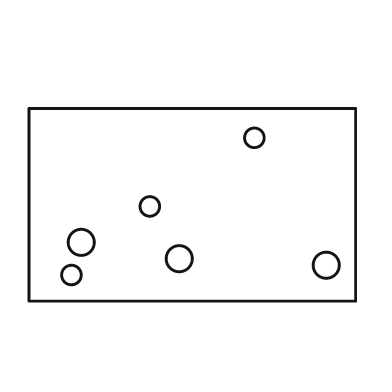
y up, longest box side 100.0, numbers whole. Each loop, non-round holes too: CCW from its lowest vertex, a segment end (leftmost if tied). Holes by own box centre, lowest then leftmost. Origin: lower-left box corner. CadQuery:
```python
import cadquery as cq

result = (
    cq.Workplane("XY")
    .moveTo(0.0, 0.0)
    .lineTo(100.0, 0.0)
    .lineTo(100.0, 59.0)
    .lineTo(0.0, 59.0)
    .close()
    .moveTo(13.0, 8.0)
    .circle(3.0)
    .moveTo(91.0, 11.0)
    .circle(4.0)
    .moveTo(46.0, 13.0)
    .circle(4.0)
    .moveTo(16.0, 18.0)
    .circle(4.0)
    .moveTo(37.0, 29.0)
    .circle(3.0)
    .moveTo(69.0, 50.0)
    .circle(3.0)
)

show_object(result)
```